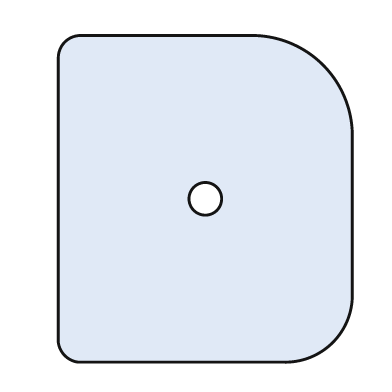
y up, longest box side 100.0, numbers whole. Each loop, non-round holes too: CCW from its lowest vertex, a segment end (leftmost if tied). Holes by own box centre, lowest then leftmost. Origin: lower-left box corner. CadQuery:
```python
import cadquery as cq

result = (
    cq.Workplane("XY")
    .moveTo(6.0, 0.0)
    .lineTo(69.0, 0.0)
    .threePointArc((84.0, 6.0), (90.0, 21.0))
    .lineTo(90.0, 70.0)
    .threePointArc((81.0, 91.0), (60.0, 100.0))
    .lineTo(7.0, 100.0)
    .threePointArc((2.0, 98.0), (0.0, 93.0))
    .lineTo(0.0, 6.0)
    .threePointArc((2.0, 2.0), (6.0, 0.0))
    .close()
    .moveTo(45.0, 50.0)
    .circle(5.0)
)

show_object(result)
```